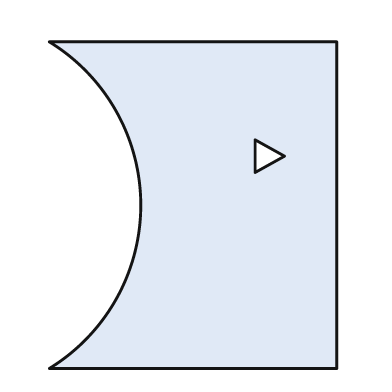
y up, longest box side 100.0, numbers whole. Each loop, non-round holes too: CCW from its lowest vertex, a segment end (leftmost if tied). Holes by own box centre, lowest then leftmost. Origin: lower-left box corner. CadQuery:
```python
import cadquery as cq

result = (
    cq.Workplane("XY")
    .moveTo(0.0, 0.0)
    .lineTo(88.0, 0.0)
    .lineTo(88.0, 100.0)
    .lineTo(0.0, 100.0)
    .threePointArc((28.0, 50.0), (0.0, 0.0))
    .close()
    .moveTo(63.0, 60.0)
    .lineTo(72.0, 65.0)
    .lineTo(63.0, 70.0)
    .close()
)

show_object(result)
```